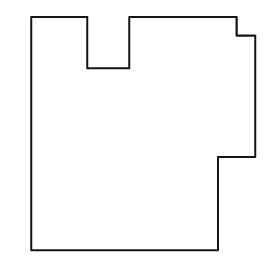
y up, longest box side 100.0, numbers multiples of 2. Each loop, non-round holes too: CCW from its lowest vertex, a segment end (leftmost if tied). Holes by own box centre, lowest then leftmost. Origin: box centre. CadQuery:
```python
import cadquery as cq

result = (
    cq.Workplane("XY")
    .moveTo(-48.0, -50.0)
    .lineTo(32.0, -50.0)
    .lineTo(32.0, -10.0)
    .lineTo(48.0, -10.0)
    .lineTo(48.0, 42.0)
    .lineTo(40.0, 42.0)
    .lineTo(40.0, 50.0)
    .lineTo(-6.0, 50.0)
    .lineTo(-6.0, 28.0)
    .lineTo(-24.0, 28.0)
    .lineTo(-24.0, 50.0)
    .lineTo(-48.0, 50.0)
    .close()
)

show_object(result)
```